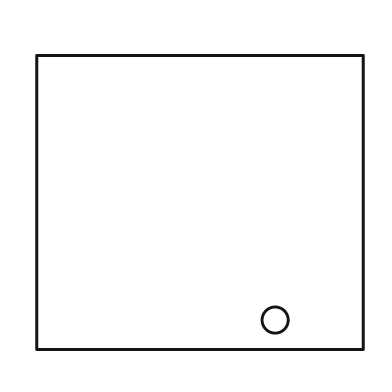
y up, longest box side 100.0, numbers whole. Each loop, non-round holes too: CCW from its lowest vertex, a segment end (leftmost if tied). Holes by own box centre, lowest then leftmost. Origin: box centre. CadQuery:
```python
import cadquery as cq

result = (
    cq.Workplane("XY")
    .moveTo(-50.0, -45.0)
    .lineTo(50.0, -45.0)
    .lineTo(50.0, 45.0)
    .lineTo(-50.0, 45.0)
    .close()
    .moveTo(23.0, -36.0)
    .circle(4.0)
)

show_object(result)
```